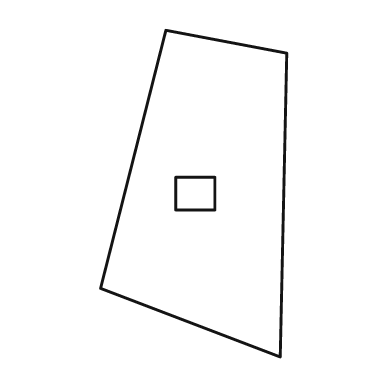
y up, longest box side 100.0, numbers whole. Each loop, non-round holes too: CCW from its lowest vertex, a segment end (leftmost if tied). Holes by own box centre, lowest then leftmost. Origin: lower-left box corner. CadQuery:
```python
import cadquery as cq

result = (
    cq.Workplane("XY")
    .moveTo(55.0, 0.0)
    .lineTo(57.0, 93.0)
    .lineTo(20.0, 100.0)
    .lineTo(0.0, 21.0)
    .close()
    .moveTo(23.0, 45.0)
    .lineTo(35.0, 45.0)
    .lineTo(35.0, 55.0)
    .lineTo(23.0, 55.0)
    .close()
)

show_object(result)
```